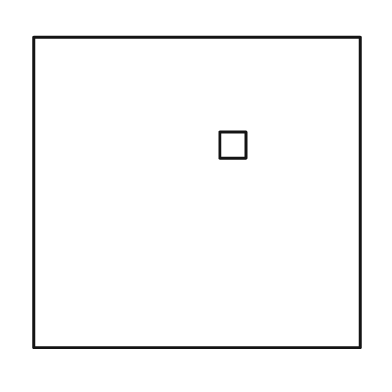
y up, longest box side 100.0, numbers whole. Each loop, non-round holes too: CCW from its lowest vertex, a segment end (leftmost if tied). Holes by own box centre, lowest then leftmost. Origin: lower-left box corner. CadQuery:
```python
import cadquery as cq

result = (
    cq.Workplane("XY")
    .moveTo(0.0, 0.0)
    .lineTo(100.0, 0.0)
    .lineTo(100.0, 95.0)
    .lineTo(0.0, 95.0)
    .close()
    .moveTo(57.0, 58.0)
    .lineTo(65.0, 58.0)
    .lineTo(65.0, 66.0)
    .lineTo(57.0, 66.0)
    .close()
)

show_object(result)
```